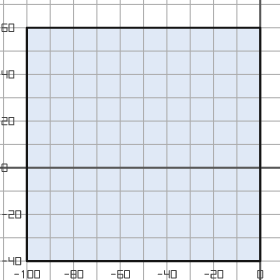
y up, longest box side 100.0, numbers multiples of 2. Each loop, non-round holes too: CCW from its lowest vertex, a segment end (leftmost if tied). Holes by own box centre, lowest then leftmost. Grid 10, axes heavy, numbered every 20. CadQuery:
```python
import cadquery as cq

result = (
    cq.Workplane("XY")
    .moveTo(-100.0, -40.0)
    .lineTo(0.0, -40.0)
    .lineTo(0.0, 60.0)
    .lineTo(-100.0, 60.0)
    .close()
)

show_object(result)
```